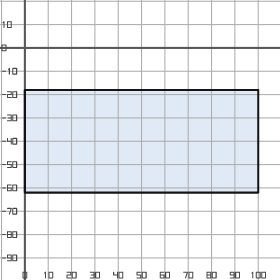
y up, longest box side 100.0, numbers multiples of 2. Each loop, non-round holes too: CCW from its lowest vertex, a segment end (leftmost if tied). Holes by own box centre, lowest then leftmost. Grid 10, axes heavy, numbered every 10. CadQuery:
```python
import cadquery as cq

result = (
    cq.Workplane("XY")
    .moveTo(0.0, -62.0)
    .lineTo(100.0, -62.0)
    .lineTo(100.0, -18.0)
    .lineTo(0.0, -18.0)
    .close()
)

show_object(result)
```